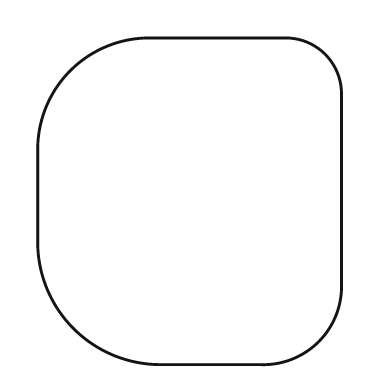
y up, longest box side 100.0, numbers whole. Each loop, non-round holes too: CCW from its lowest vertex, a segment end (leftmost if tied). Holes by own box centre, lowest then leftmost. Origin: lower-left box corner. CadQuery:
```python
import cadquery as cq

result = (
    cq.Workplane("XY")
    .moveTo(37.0, 0.0)
    .lineTo(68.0, 0.0)
    .threePointArc((86.0, 7.0), (93.0, 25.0))
    .lineTo(93.0, 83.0)
    .threePointArc((88.0, 95.0), (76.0, 100.0))
    .lineTo(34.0, 100.0)
    .threePointArc((10.0, 90.0), (0.0, 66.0))
    .lineTo(0.0, 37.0)
    .threePointArc((11.0, 11.0), (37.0, 0.0))
    .close()
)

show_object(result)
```